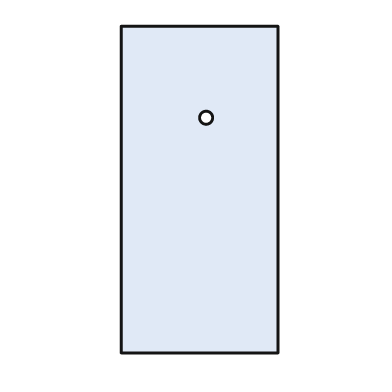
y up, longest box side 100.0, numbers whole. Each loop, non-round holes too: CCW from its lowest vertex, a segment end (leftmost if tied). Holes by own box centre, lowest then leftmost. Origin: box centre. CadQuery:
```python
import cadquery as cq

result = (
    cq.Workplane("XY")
    .moveTo(-24.0, -50.0)
    .lineTo(24.0, -50.0)
    .lineTo(24.0, 50.0)
    .lineTo(-24.0, 50.0)
    .close()
    .moveTo(2.0, 22.0)
    .circle(2.0)
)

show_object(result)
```